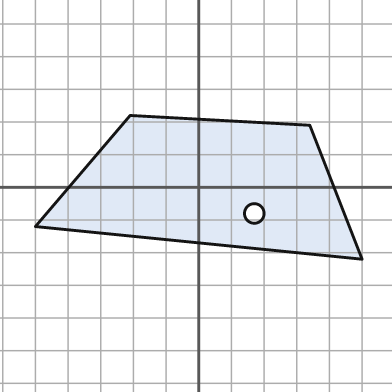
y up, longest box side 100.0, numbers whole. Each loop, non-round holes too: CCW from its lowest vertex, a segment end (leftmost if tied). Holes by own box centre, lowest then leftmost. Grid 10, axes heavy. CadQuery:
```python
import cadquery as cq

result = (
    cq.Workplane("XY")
    .moveTo(50.0, -22.0)
    .lineTo(34.0, 19.0)
    .lineTo(-21.0, 22.0)
    .lineTo(-50.0, -12.0)
    .close()
    .moveTo(17.0, -8.0)
    .circle(3.0)
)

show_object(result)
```